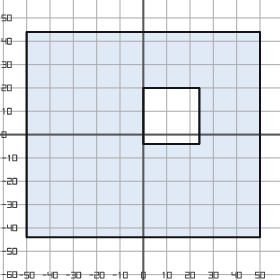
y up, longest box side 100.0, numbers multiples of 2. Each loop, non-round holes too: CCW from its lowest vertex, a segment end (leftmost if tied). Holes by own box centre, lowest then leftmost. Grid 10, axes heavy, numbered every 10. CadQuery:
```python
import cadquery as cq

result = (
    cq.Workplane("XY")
    .moveTo(-50.0, -44.0)
    .lineTo(50.0, -44.0)
    .lineTo(50.0, 44.0)
    .lineTo(-50.0, 44.0)
    .close()
    .moveTo(0.0, -4.0)
    .lineTo(24.0, -4.0)
    .lineTo(24.0, 20.0)
    .lineTo(0.0, 20.0)
    .close()
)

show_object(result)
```